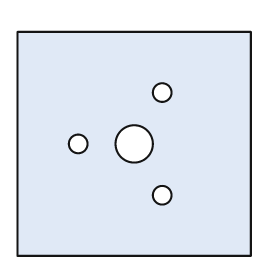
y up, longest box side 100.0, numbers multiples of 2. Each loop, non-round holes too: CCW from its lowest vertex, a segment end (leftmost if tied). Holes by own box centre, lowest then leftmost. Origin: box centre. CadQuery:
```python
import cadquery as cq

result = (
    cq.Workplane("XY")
    .moveTo(-50.0, -48.0)
    .lineTo(50.0, -48.0)
    .lineTo(50.0, 48.0)
    .lineTo(-50.0, 48.0)
    .close()
    .moveTo(12.0, -22.0)
    .circle(4.0)
    .moveTo(-24.0, 0.0)
    .circle(4.0)
    .moveTo(0.0, 0.0)
    .circle(8.0)
    .moveTo(12.0, 22.0)
    .circle(4.0)
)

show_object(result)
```